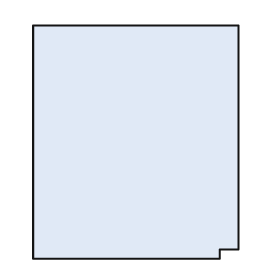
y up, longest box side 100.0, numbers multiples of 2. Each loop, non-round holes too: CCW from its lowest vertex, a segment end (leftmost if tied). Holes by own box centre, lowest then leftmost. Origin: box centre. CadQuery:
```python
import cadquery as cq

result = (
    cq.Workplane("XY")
    .moveTo(-44.0, -50.0)
    .lineTo(36.0, -50.0)
    .lineTo(36.0, -46.0)
    .lineTo(44.0, -46.0)
    .lineTo(44.0, 50.0)
    .lineTo(-44.0, 50.0)
    .close()
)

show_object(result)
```